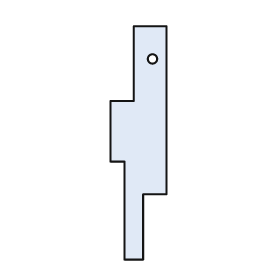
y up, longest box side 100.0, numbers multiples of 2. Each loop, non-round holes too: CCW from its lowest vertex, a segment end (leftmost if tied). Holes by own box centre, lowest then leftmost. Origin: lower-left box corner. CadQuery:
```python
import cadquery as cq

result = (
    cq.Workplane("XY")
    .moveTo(6.0, 0.0)
    .lineTo(14.0, 0.0)
    .lineTo(14.0, 28.0)
    .lineTo(24.0, 28.0)
    .lineTo(24.0, 100.0)
    .lineTo(10.0, 100.0)
    .lineTo(10.0, 68.0)
    .lineTo(0.0, 68.0)
    .lineTo(0.0, 42.0)
    .lineTo(6.0, 42.0)
    .close()
    .moveTo(18.0, 86.0)
    .circle(2.0)
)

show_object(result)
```